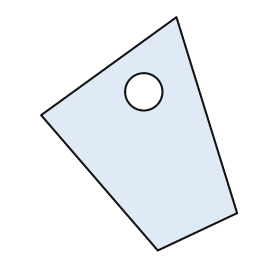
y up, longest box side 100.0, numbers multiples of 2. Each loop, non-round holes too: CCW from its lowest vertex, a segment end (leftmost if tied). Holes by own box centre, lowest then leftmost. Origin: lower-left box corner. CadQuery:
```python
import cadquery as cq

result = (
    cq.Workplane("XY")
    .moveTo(50.0, 0.0)
    .lineTo(84.0, 16.0)
    .lineTo(58.0, 100.0)
    .lineTo(0.0, 58.0)
    .close()
    .moveTo(44.0, 68.0)
    .circle(8.0)
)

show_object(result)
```